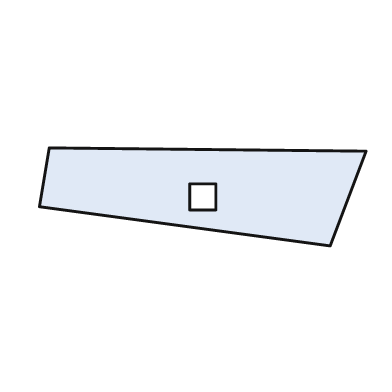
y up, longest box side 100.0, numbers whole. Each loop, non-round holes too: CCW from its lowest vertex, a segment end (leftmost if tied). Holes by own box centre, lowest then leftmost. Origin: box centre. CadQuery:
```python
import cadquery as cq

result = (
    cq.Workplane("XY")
    .moveTo(39.0, -15.0)
    .lineTo(50.0, 14.0)
    .lineTo(-47.0, 15.0)
    .lineTo(-50.0, -3.0)
    .close()
    .moveTo(-4.0, -4.0)
    .lineTo(4.0, -4.0)
    .lineTo(4.0, 4.0)
    .lineTo(-4.0, 4.0)
    .close()
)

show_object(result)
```